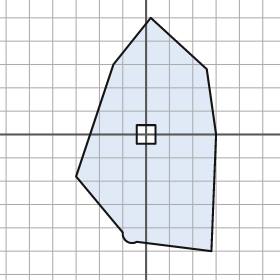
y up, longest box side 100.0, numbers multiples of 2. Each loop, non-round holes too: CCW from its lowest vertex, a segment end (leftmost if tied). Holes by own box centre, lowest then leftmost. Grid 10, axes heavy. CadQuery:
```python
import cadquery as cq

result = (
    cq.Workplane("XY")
    .moveTo(28.0, -50.0)
    .lineTo(30.0, 0.0)
    .lineTo(26.0, 28.0)
    .lineTo(2.0, 50.0)
    .lineTo(-14.0, 30.0)
    .lineTo(-30.0, -18.0)
    .lineTo(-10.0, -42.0)
    .threePointArc((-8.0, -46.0), (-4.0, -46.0))
    .close()
    .moveTo(-4.0, -4.0)
    .lineTo(4.0, -4.0)
    .lineTo(4.0, 4.0)
    .lineTo(-4.0, 4.0)
    .close()
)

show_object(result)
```